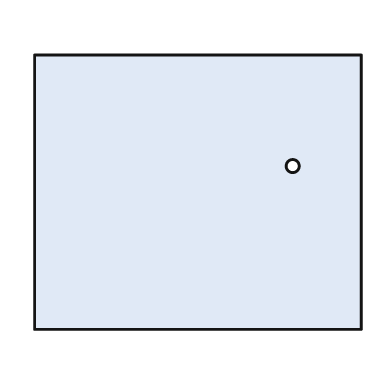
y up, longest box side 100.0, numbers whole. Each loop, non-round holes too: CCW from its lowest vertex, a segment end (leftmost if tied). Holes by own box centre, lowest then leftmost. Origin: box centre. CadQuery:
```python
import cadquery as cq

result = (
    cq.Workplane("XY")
    .moveTo(-50.0, -42.0)
    .lineTo(50.0, -42.0)
    .lineTo(50.0, 42.0)
    .lineTo(-50.0, 42.0)
    .close()
    .moveTo(29.0, 8.0)
    .circle(2.0)
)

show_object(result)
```